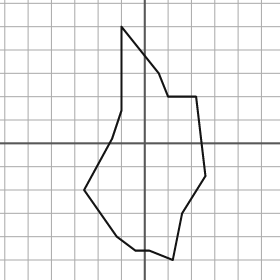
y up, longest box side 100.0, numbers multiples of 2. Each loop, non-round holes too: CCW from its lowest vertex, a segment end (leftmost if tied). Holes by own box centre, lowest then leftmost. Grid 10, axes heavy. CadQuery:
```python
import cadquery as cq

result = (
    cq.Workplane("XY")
    .moveTo(12.0, -50.0)
    .lineTo(16.0, -30.0)
    .lineTo(26.0, -14.0)
    .lineTo(22.0, 20.0)
    .lineTo(10.0, 20.0)
    .lineTo(6.0, 30.0)
    .lineTo(-10.0, 50.0)
    .lineTo(-10.0, 14.0)
    .lineTo(-14.0, 2.0)
    .lineTo(-26.0, -20.0)
    .lineTo(-12.0, -40.0)
    .lineTo(-4.0, -46.0)
    .lineTo(2.0, -46.0)
    .close()
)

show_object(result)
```